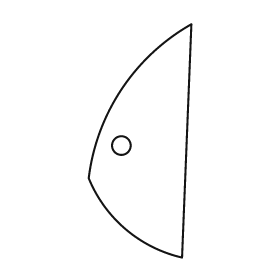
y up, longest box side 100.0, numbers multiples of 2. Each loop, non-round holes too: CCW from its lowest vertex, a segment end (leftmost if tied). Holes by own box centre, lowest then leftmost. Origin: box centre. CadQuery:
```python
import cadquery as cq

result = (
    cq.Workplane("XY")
    .moveTo(18.0, -50.0)
    .lineTo(22.0, 50.0)
    .threePointArc((-8.0, 22.0), (-22.0, -16.0))
    .threePointArc((-6.0, -38.0), (18.0, -50.0))
    .close()
    .moveTo(-8.0, -2.0)
    .circle(4.0)
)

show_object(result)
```